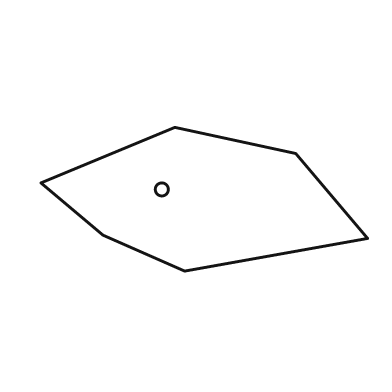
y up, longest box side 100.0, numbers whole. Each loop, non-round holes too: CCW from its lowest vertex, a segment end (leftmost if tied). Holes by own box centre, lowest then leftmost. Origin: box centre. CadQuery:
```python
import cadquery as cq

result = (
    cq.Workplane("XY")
    .moveTo(-6.0, -22.0)
    .lineTo(50.0, -12.0)
    .lineTo(28.0, 14.0)
    .lineTo(-9.0, 22.0)
    .lineTo(-50.0, 5.0)
    .lineTo(-31.0, -11.0)
    .close()
    .moveTo(-13.0, 3.0)
    .circle(2.0)
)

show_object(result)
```